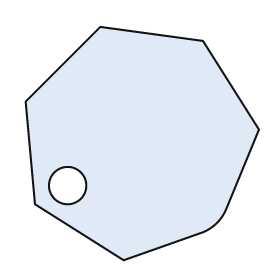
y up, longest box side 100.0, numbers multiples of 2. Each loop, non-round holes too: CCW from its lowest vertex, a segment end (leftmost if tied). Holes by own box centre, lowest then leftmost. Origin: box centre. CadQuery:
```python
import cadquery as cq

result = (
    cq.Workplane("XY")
    .moveTo(-8.0, -50.0)
    .lineTo(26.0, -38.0)
    .threePointArc((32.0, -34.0), (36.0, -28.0))
    .lineTo(50.0, 6.0)
    .lineTo(26.0, 44.0)
    .lineTo(-18.0, 50.0)
    .lineTo(-50.0, 18.0)
    .lineTo(-46.0, -26.0)
    .close()
    .moveTo(-32.0, -18.0)
    .circle(8.0)
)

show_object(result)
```